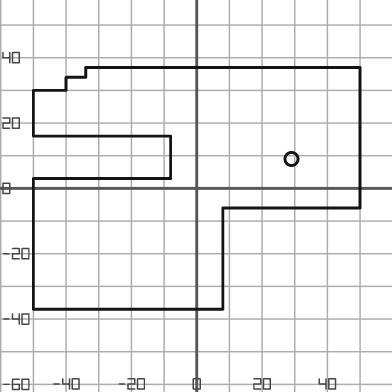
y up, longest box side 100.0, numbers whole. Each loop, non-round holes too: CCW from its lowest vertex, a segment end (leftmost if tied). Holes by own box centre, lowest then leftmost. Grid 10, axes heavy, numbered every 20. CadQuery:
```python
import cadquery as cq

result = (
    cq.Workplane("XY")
    .moveTo(-50.0, -37.0)
    .lineTo(8.0, -37.0)
    .lineTo(8.0, -6.0)
    .lineTo(50.0, -6.0)
    .lineTo(50.0, 37.0)
    .lineTo(-34.0, 37.0)
    .lineTo(-34.0, 34.0)
    .lineTo(-40.0, 34.0)
    .lineTo(-40.0, 30.0)
    .lineTo(-50.0, 30.0)
    .lineTo(-50.0, 16.0)
    .lineTo(-8.0, 16.0)
    .lineTo(-8.0, 3.0)
    .lineTo(-50.0, 3.0)
    .close()
    .moveTo(29.0, 9.0)
    .circle(2.0)
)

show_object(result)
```